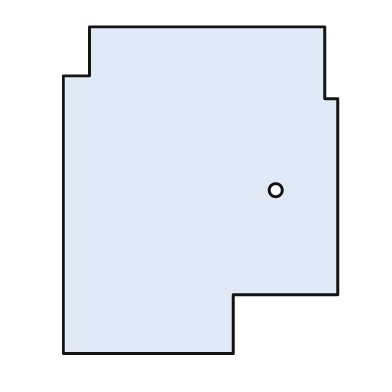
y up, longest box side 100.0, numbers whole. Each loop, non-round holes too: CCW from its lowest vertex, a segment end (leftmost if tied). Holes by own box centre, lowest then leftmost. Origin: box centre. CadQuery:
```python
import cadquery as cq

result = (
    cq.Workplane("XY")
    .moveTo(-42.0, -50.0)
    .lineTo(10.0, -50.0)
    .lineTo(10.0, -32.0)
    .lineTo(42.0, -32.0)
    .lineTo(42.0, 28.0)
    .lineTo(38.0, 28.0)
    .lineTo(38.0, 50.0)
    .lineTo(-34.0, 50.0)
    .lineTo(-34.0, 35.0)
    .lineTo(-42.0, 35.0)
    .close()
    .moveTo(23.0, 0.0)
    .circle(2.0)
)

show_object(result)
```